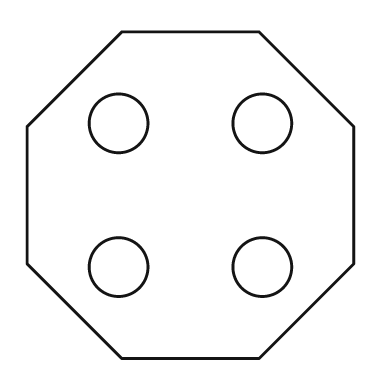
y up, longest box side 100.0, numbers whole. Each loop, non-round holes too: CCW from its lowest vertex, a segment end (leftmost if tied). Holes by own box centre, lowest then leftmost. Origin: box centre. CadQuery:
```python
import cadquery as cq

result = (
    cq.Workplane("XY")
    .moveTo(-21.0, -50.0)
    .lineTo(21.0, -50.0)
    .lineTo(50.0, -21.0)
    .lineTo(50.0, 21.0)
    .lineTo(21.0, 50.0)
    .lineTo(-21.0, 50.0)
    .lineTo(-50.0, 21.0)
    .lineTo(-50.0, -21.0)
    .close()
    .moveTo(-22.0, -22.0)
    .circle(9.0)
    .moveTo(22.0, -22.0)
    .circle(9.0)
    .moveTo(-22.0, 22.0)
    .circle(9.0)
    .moveTo(22.0, 22.0)
    .circle(9.0)
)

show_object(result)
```